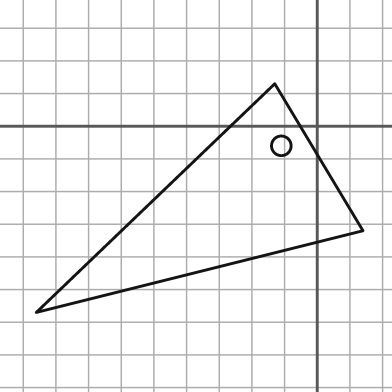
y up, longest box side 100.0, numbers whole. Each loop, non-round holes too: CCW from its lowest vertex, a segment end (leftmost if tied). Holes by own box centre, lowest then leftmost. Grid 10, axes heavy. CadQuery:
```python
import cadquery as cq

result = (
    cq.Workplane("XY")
    .moveTo(-86.0, -57.0)
    .lineTo(14.0, -32.0)
    .lineTo(-13.0, 13.0)
    .close()
    .moveTo(-11.0, -6.0)
    .circle(3.0)
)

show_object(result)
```